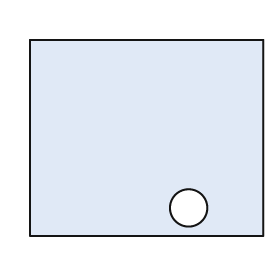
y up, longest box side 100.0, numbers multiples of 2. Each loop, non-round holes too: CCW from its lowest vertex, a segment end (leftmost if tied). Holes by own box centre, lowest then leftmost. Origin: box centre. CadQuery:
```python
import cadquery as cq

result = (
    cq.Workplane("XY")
    .moveTo(-50.0, -42.0)
    .lineTo(50.0, -42.0)
    .lineTo(50.0, 42.0)
    .lineTo(-50.0, 42.0)
    .close()
    .moveTo(18.0, -30.0)
    .circle(8.0)
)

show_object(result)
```